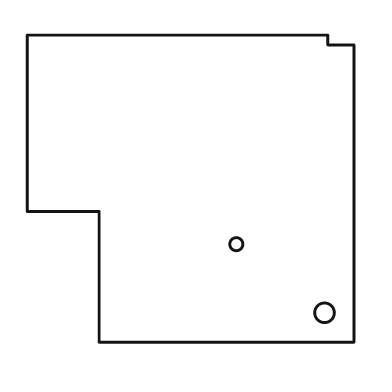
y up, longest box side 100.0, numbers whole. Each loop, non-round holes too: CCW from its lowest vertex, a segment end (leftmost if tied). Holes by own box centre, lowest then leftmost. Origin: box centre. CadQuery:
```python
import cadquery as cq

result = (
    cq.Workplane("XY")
    .moveTo(-28.0, -47.0)
    .lineTo(50.0, -47.0)
    .lineTo(50.0, 44.0)
    .lineTo(42.0, 44.0)
    .lineTo(42.0, 47.0)
    .lineTo(-50.0, 47.0)
    .lineTo(-50.0, -7.0)
    .lineTo(-28.0, -7.0)
    .close()
    .moveTo(41.0, -38.0)
    .circle(3.0)
    .moveTo(14.0, -17.0)
    .circle(2.0)
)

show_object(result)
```